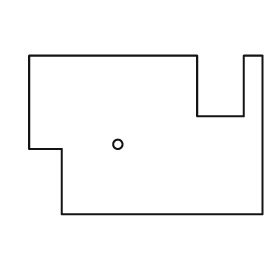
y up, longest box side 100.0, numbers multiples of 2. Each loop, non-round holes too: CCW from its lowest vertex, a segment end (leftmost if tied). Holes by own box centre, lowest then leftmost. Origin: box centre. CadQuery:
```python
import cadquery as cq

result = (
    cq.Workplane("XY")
    .moveTo(-36.0, -34.0)
    .lineTo(50.0, -34.0)
    .lineTo(50.0, 34.0)
    .lineTo(42.0, 34.0)
    .lineTo(42.0, 8.0)
    .lineTo(22.0, 8.0)
    .lineTo(22.0, 34.0)
    .lineTo(-50.0, 34.0)
    .lineTo(-50.0, -6.0)
    .lineTo(-36.0, -6.0)
    .close()
    .moveTo(-12.0, -4.0)
    .circle(2.0)
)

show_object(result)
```